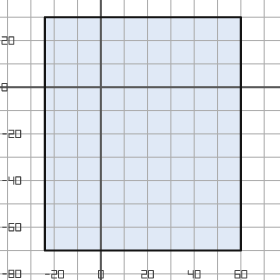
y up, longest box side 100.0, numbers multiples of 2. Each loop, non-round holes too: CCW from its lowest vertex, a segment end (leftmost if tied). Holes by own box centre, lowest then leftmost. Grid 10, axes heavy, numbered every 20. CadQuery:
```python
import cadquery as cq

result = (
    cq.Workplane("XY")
    .moveTo(-24.0, -70.0)
    .lineTo(60.0, -70.0)
    .lineTo(60.0, 30.0)
    .lineTo(-24.0, 30.0)
    .close()
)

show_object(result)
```